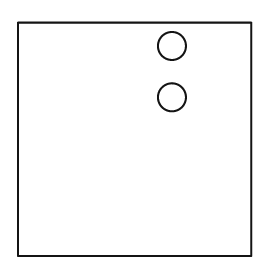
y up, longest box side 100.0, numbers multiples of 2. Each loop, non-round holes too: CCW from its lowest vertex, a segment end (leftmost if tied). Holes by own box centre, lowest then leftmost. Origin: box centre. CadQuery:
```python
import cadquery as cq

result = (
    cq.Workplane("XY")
    .moveTo(-50.0, -50.0)
    .lineTo(50.0, -50.0)
    .lineTo(50.0, 50.0)
    .lineTo(-50.0, 50.0)
    .close()
    .moveTo(16.0, 18.0)
    .circle(6.0)
    .moveTo(16.0, 40.0)
    .circle(6.0)
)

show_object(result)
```